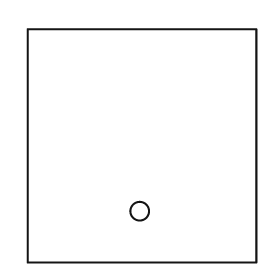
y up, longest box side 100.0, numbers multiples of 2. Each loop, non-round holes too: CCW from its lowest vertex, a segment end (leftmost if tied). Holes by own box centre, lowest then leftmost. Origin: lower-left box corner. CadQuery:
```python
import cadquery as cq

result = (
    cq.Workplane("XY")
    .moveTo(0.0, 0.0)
    .lineTo(98.0, 0.0)
    .lineTo(98.0, 100.0)
    .lineTo(0.0, 100.0)
    .close()
    .moveTo(48.0, 22.0)
    .circle(4.0)
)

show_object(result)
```